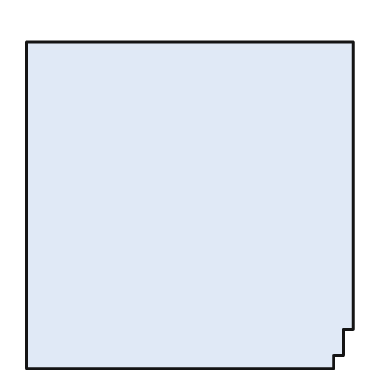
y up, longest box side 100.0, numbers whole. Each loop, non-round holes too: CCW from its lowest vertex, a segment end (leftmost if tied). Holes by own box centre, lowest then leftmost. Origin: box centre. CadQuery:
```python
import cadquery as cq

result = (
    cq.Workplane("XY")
    .moveTo(-50.0, -50.0)
    .lineTo(44.0, -50.0)
    .lineTo(44.0, -46.0)
    .lineTo(47.0, -46.0)
    .lineTo(47.0, -38.0)
    .lineTo(50.0, -38.0)
    .lineTo(50.0, 50.0)
    .lineTo(-50.0, 50.0)
    .close()
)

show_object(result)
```